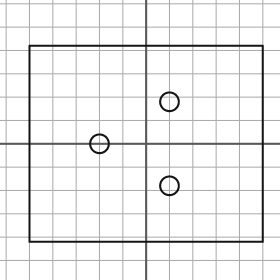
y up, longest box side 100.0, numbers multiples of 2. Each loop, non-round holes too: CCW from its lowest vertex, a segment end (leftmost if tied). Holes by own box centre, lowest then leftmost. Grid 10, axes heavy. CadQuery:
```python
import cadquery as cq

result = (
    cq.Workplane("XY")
    .moveTo(-50.0, -42.0)
    .lineTo(50.0, -42.0)
    .lineTo(50.0, 42.0)
    .lineTo(-50.0, 42.0)
    .close()
    .moveTo(10.0, -18.0)
    .circle(4.0)
    .moveTo(-20.0, 0.0)
    .circle(4.0)
    .moveTo(10.0, 18.0)
    .circle(4.0)
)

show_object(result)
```